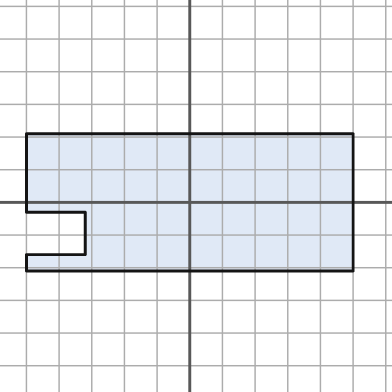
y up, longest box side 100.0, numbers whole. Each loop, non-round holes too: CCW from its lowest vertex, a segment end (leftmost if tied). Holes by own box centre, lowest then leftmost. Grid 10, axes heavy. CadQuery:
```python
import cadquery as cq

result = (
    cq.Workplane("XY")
    .moveTo(-50.0, -21.0)
    .lineTo(50.0, -21.0)
    .lineTo(50.0, 21.0)
    .lineTo(-50.0, 21.0)
    .lineTo(-50.0, -3.0)
    .lineTo(-32.0, -3.0)
    .lineTo(-32.0, -16.0)
    .lineTo(-50.0, -16.0)
    .close()
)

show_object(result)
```